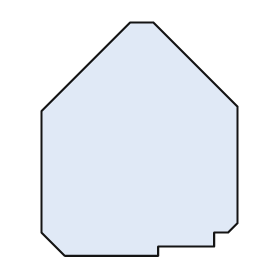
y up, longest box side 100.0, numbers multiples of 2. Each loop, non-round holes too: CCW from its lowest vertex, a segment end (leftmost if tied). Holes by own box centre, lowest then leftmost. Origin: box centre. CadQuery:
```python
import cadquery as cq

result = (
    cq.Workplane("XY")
    .moveTo(-32.0, -50.0)
    .lineTo(8.0, -50.0)
    .lineTo(8.0, -46.0)
    .lineTo(32.0, -46.0)
    .lineTo(32.0, -40.0)
    .lineTo(38.0, -40.0)
    .lineTo(42.0, -36.0)
    .lineTo(42.0, 14.0)
    .lineTo(6.0, 50.0)
    .lineTo(-4.0, 50.0)
    .lineTo(-42.0, 12.0)
    .lineTo(-42.0, -40.0)
    .close()
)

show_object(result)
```